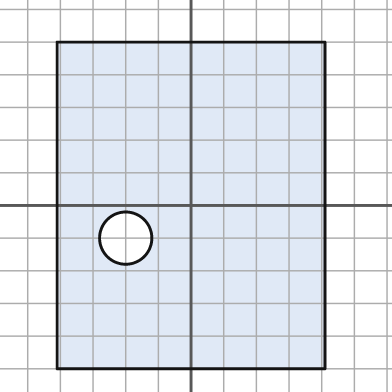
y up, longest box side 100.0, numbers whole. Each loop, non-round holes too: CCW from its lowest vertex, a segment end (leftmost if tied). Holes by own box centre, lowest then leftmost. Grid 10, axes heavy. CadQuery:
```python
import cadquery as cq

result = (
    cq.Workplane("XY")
    .moveTo(-41.0, -50.0)
    .lineTo(41.0, -50.0)
    .lineTo(41.0, 50.0)
    .lineTo(-41.0, 50.0)
    .close()
    .moveTo(-20.0, -10.0)
    .circle(8.0)
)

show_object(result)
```